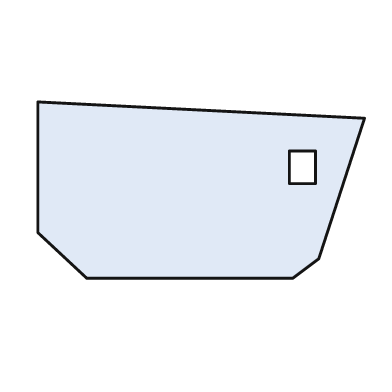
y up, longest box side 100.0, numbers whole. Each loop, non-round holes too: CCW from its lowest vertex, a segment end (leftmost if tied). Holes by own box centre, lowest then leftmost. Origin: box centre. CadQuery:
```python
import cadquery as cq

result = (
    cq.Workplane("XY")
    .moveTo(-35.0, -27.0)
    .lineTo(28.0, -27.0)
    .lineTo(36.0, -21.0)
    .lineTo(50.0, 22.0)
    .lineTo(-50.0, 27.0)
    .lineTo(-50.0, -13.0)
    .close()
    .moveTo(27.0, 2.0)
    .lineTo(35.0, 2.0)
    .lineTo(35.0, 12.0)
    .lineTo(27.0, 12.0)
    .close()
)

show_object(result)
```